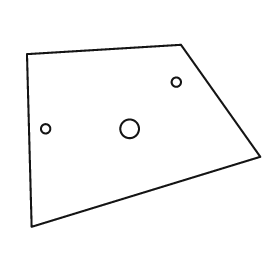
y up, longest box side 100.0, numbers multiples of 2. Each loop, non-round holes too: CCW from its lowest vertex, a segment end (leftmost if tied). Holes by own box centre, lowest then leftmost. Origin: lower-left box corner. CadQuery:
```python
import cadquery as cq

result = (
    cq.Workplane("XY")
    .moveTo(2.0, 0.0)
    .lineTo(100.0, 30.0)
    .lineTo(66.0, 78.0)
    .lineTo(0.0, 74.0)
    .close()
    .moveTo(8.0, 42.0)
    .circle(2.0)
    .moveTo(44.0, 42.0)
    .circle(4.0)
    .moveTo(64.0, 62.0)
    .circle(2.0)
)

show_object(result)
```